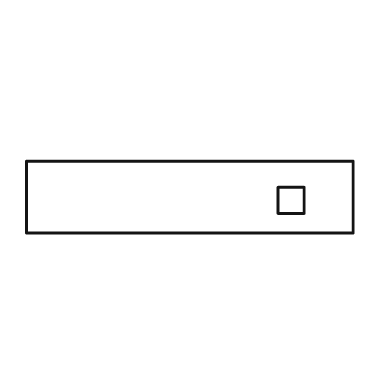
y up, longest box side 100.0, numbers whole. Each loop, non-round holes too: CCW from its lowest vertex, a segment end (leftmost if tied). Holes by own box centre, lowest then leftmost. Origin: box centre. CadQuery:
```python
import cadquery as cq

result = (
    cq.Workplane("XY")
    .moveTo(-50.0, -11.0)
    .lineTo(50.0, -11.0)
    .lineTo(50.0, 11.0)
    .lineTo(-50.0, 11.0)
    .close()
    .moveTo(27.0, -5.0)
    .lineTo(35.0, -5.0)
    .lineTo(35.0, 3.0)
    .lineTo(27.0, 3.0)
    .close()
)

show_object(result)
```